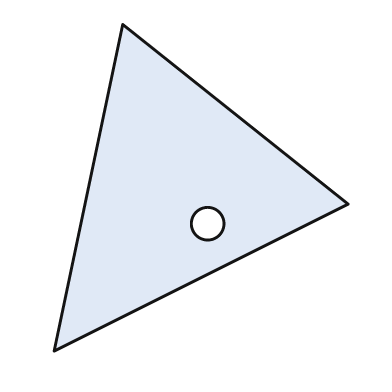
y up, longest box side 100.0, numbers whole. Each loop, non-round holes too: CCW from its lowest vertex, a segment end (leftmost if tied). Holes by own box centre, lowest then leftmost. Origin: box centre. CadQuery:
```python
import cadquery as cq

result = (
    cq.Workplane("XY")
    .moveTo(-45.0, -50.0)
    .lineTo(45.0, -5.0)
    .lineTo(-24.0, 50.0)
    .close()
    .moveTo(2.0, -11.0)
    .circle(5.0)
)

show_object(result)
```